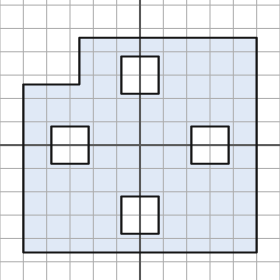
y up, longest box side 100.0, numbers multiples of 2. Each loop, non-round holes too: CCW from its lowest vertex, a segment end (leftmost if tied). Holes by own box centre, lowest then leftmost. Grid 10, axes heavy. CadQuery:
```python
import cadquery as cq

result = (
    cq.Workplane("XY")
    .moveTo(-50.0, -46.0)
    .lineTo(50.0, -46.0)
    .lineTo(50.0, 46.0)
    .lineTo(-26.0, 46.0)
    .lineTo(-26.0, 26.0)
    .lineTo(-50.0, 26.0)
    .close()
    .moveTo(-8.0, -38.0)
    .lineTo(8.0, -38.0)
    .lineTo(8.0, -22.0)
    .lineTo(-8.0, -22.0)
    .close()
    .moveTo(-38.0, -8.0)
    .lineTo(-22.0, -8.0)
    .lineTo(-22.0, 8.0)
    .lineTo(-38.0, 8.0)
    .close()
    .moveTo(22.0, -8.0)
    .lineTo(38.0, -8.0)
    .lineTo(38.0, 8.0)
    .lineTo(22.0, 8.0)
    .close()
    .moveTo(-8.0, 22.0)
    .lineTo(8.0, 22.0)
    .lineTo(8.0, 38.0)
    .lineTo(-8.0, 38.0)
    .close()
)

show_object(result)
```